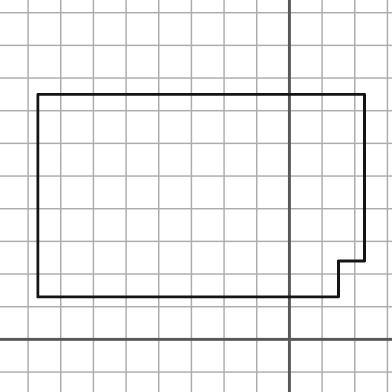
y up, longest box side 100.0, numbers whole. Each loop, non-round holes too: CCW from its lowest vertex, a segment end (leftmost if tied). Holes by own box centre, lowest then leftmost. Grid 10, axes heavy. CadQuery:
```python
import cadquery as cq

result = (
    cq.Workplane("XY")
    .moveTo(-77.0, 13.0)
    .lineTo(15.0, 13.0)
    .lineTo(15.0, 24.0)
    .lineTo(23.0, 24.0)
    .lineTo(23.0, 75.0)
    .lineTo(-77.0, 75.0)
    .close()
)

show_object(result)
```